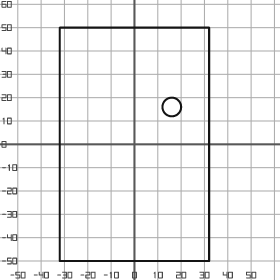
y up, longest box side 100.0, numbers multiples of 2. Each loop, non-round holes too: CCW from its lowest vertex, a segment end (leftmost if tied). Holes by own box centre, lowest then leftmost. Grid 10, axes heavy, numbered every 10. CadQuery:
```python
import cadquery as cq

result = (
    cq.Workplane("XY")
    .moveTo(-32.0, -50.0)
    .lineTo(32.0, -50.0)
    .lineTo(32.0, 50.0)
    .lineTo(-32.0, 50.0)
    .close()
    .moveTo(16.0, 16.0)
    .circle(4.0)
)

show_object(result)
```